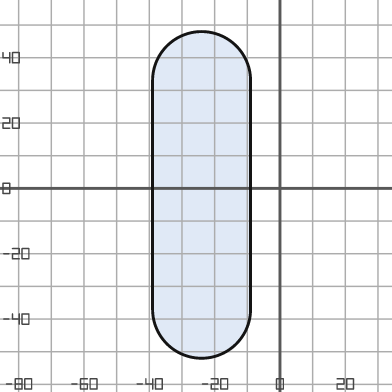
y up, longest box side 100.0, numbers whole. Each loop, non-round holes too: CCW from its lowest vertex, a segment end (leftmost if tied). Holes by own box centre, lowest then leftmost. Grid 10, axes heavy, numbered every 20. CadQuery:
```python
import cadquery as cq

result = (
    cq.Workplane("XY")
    .moveTo(-39.0, -37.0)
    .threePointArc((-24.0, -52.0), (-9.0, -37.0))
    .lineTo(-9.0, 33.0)
    .threePointArc((-24.0, 48.0), (-39.0, 33.0))
    .close()
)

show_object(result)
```